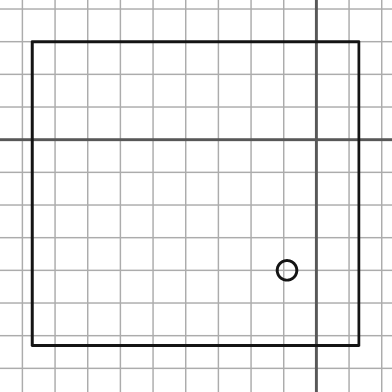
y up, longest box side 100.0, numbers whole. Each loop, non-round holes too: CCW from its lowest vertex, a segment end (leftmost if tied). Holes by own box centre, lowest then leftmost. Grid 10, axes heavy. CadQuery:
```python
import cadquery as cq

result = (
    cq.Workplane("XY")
    .moveTo(-87.0, -63.0)
    .lineTo(13.0, -63.0)
    .lineTo(13.0, 30.0)
    .lineTo(-87.0, 30.0)
    .close()
    .moveTo(-9.0, -40.0)
    .circle(3.0)
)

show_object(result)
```